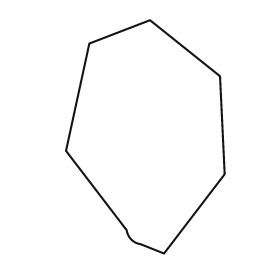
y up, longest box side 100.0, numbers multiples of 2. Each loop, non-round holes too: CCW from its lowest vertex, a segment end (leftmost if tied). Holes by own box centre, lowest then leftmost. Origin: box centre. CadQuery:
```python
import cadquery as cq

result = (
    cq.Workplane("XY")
    .moveTo(8.0, -50.0)
    .lineTo(34.0, -16.0)
    .lineTo(32.0, 26.0)
    .lineTo(2.0, 50.0)
    .lineTo(-24.0, 40.0)
    .lineTo(-34.0, -6.0)
    .lineTo(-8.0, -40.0)
    .threePointArc((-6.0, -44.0), (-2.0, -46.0))
    .close()
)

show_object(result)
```